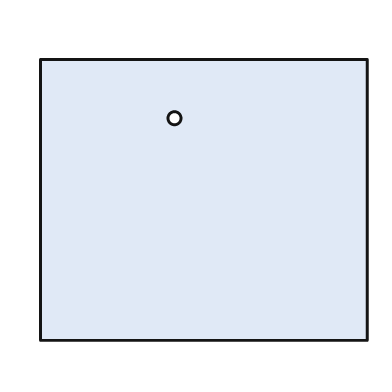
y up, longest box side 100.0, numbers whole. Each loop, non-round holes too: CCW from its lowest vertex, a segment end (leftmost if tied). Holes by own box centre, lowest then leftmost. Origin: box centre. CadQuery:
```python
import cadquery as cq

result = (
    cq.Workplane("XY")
    .moveTo(-50.0, -43.0)
    .lineTo(50.0, -43.0)
    .lineTo(50.0, 43.0)
    .lineTo(-50.0, 43.0)
    .close()
    .moveTo(-9.0, 25.0)
    .circle(2.0)
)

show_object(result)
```